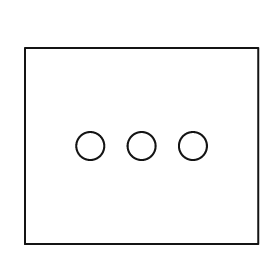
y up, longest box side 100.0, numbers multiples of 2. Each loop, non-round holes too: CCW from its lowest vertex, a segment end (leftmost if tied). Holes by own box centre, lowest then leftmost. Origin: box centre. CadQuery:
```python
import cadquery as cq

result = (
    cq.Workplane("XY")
    .moveTo(-50.0, -42.0)
    .lineTo(50.0, -42.0)
    .lineTo(50.0, 42.0)
    .lineTo(-50.0, 42.0)
    .close()
    .moveTo(-22.0, 0.0)
    .circle(6.0)
    .moveTo(0.0, 0.0)
    .circle(6.0)
    .moveTo(22.0, 0.0)
    .circle(6.0)
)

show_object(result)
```